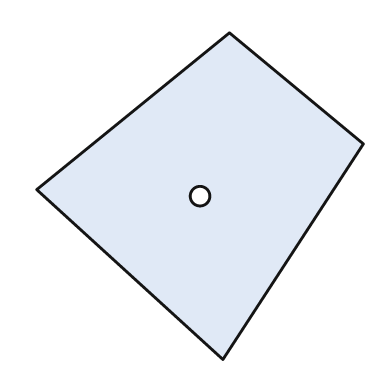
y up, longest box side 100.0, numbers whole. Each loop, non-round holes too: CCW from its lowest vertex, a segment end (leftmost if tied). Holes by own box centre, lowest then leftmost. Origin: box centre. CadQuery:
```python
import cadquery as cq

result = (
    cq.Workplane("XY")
    .moveTo(7.0, -50.0)
    .lineTo(50.0, 16.0)
    .lineTo(9.0, 50.0)
    .lineTo(-50.0, 2.0)
    .close()
    .moveTo(0.0, 0.0)
    .circle(3.0)
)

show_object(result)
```